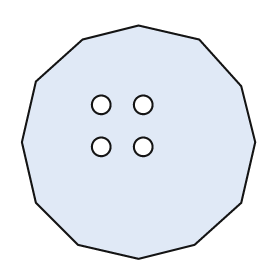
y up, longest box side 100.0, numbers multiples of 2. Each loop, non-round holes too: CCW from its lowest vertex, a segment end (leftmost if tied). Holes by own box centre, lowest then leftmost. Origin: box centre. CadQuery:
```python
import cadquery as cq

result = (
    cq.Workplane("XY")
    .moveTo(0.0, -50.0)
    .lineTo(24.0, -44.0)
    .lineTo(44.0, -26.0)
    .lineTo(50.0, 0.0)
    .lineTo(44.0, 24.0)
    .lineTo(26.0, 44.0)
    .lineTo(0.0, 50.0)
    .lineTo(-24.0, 44.0)
    .lineTo(-44.0, 26.0)
    .lineTo(-50.0, 0.0)
    .lineTo(-44.0, -26.0)
    .lineTo(-26.0, -44.0)
    .close()
    .moveTo(-16.0, -2.0)
    .circle(4.0)
    .moveTo(2.0, -2.0)
    .circle(4.0)
    .moveTo(-16.0, 16.0)
    .circle(4.0)
    .moveTo(2.0, 16.0)
    .circle(4.0)
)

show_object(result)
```